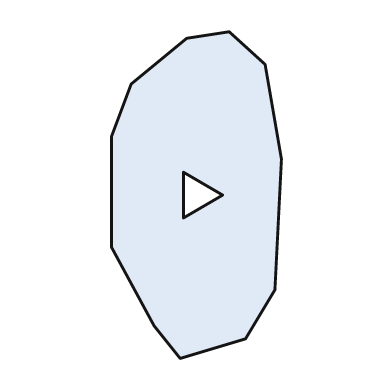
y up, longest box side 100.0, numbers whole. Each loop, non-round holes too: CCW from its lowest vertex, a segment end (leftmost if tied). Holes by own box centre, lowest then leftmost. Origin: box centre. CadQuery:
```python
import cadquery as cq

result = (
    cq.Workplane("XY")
    .moveTo(-5.0, -50.0)
    .lineTo(15.0, -44.0)
    .lineTo(24.0, -29.0)
    .lineTo(26.0, 11.0)
    .lineTo(21.0, 40.0)
    .lineTo(10.0, 50.0)
    .lineTo(-3.0, 48.0)
    .lineTo(-20.0, 34.0)
    .lineTo(-26.0, 18.0)
    .lineTo(-26.0, -16.0)
    .lineTo(-13.0, -40.0)
    .close()
    .moveTo(-4.0, -7.0)
    .lineTo(8.0, 0.0)
    .lineTo(-4.0, 7.0)
    .close()
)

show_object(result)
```